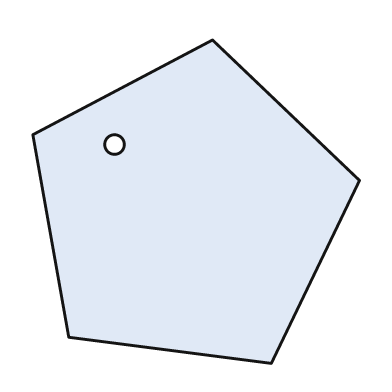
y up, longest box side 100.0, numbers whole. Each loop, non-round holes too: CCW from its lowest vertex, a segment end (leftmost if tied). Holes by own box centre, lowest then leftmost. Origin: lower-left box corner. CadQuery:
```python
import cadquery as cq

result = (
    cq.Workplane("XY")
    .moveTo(73.0, 0.0)
    .lineTo(100.0, 56.0)
    .lineTo(55.0, 99.0)
    .lineTo(0.0, 70.0)
    .lineTo(11.0, 8.0)
    .close()
    .moveTo(25.0, 67.0)
    .circle(3.0)
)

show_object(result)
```